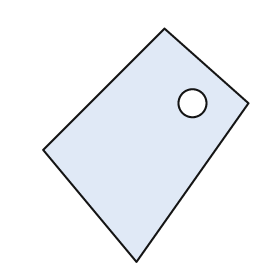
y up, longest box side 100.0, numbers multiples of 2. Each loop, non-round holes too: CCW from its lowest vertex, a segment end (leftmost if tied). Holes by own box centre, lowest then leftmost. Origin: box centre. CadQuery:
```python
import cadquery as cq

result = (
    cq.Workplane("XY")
    .moveTo(-4.0, -50.0)
    .lineTo(44.0, 18.0)
    .lineTo(8.0, 50.0)
    .lineTo(-44.0, -2.0)
    .close()
    .moveTo(20.0, 18.0)
    .circle(6.0)
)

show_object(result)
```